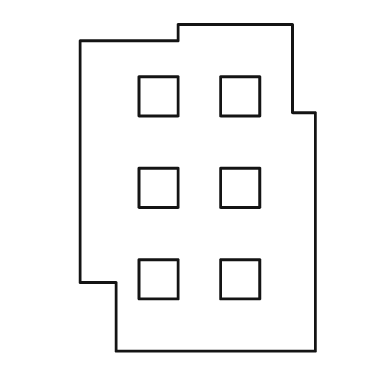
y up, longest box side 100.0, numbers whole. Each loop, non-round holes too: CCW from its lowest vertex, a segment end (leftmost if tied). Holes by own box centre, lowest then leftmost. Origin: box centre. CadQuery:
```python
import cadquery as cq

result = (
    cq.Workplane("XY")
    .moveTo(-25.0, -50.0)
    .lineTo(36.0, -50.0)
    .lineTo(36.0, 23.0)
    .lineTo(29.0, 23.0)
    .lineTo(29.0, 50.0)
    .lineTo(-6.0, 50.0)
    .lineTo(-6.0, 45.0)
    .lineTo(-36.0, 45.0)
    .lineTo(-36.0, -29.0)
    .lineTo(-25.0, -29.0)
    .close()
    .moveTo(-18.0, -34.0)
    .lineTo(-6.0, -34.0)
    .lineTo(-6.0, -22.0)
    .lineTo(-18.0, -22.0)
    .close()
    .moveTo(7.0, -34.0)
    .lineTo(19.0, -34.0)
    .lineTo(19.0, -22.0)
    .lineTo(7.0, -22.0)
    .close()
    .moveTo(-18.0, -6.0)
    .lineTo(-6.0, -6.0)
    .lineTo(-6.0, 6.0)
    .lineTo(-18.0, 6.0)
    .close()
    .moveTo(7.0, -6.0)
    .lineTo(19.0, -6.0)
    .lineTo(19.0, 6.0)
    .lineTo(7.0, 6.0)
    .close()
    .moveTo(-18.0, 22.0)
    .lineTo(-6.0, 22.0)
    .lineTo(-6.0, 34.0)
    .lineTo(-18.0, 34.0)
    .close()
    .moveTo(7.0, 22.0)
    .lineTo(19.0, 22.0)
    .lineTo(19.0, 34.0)
    .lineTo(7.0, 34.0)
    .close()
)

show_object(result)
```